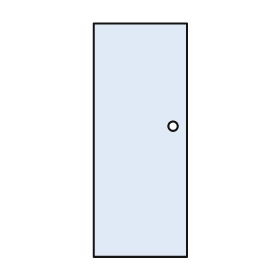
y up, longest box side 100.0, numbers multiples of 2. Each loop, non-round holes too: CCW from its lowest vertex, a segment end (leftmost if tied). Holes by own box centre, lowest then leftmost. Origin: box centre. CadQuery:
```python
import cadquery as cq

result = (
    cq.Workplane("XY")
    .moveTo(-20.0, -50.0)
    .lineTo(20.0, -50.0)
    .lineTo(20.0, 50.0)
    .lineTo(-20.0, 50.0)
    .close()
    .moveTo(14.0, 6.0)
    .circle(2.0)
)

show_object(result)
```